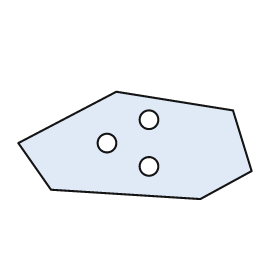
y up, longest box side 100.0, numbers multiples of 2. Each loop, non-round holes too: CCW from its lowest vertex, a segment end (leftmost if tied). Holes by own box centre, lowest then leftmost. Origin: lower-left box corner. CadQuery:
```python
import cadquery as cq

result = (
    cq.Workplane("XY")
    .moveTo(78.0, 0.0)
    .lineTo(100.0, 12.0)
    .lineTo(92.0, 38.0)
    .lineTo(42.0, 46.0)
    .lineTo(0.0, 24.0)
    .lineTo(14.0, 4.0)
    .close()
    .moveTo(56.0, 14.0)
    .circle(4.0)
    .moveTo(38.0, 24.0)
    .circle(4.0)
    .moveTo(56.0, 34.0)
    .circle(4.0)
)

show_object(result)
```